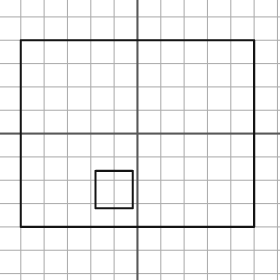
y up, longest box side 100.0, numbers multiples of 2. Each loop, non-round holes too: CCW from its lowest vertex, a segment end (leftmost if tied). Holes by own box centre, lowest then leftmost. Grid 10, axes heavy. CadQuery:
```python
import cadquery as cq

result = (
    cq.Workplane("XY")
    .moveTo(-50.0, -40.0)
    .lineTo(50.0, -40.0)
    .lineTo(50.0, 40.0)
    .lineTo(-50.0, 40.0)
    .close()
    .moveTo(-18.0, -32.0)
    .lineTo(-2.0, -32.0)
    .lineTo(-2.0, -16.0)
    .lineTo(-18.0, -16.0)
    .close()
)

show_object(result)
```